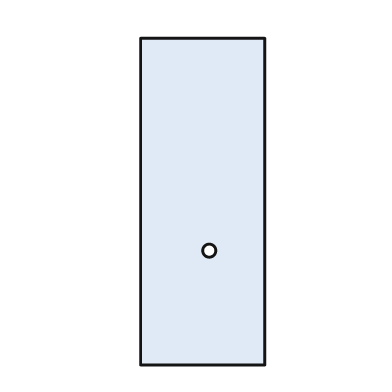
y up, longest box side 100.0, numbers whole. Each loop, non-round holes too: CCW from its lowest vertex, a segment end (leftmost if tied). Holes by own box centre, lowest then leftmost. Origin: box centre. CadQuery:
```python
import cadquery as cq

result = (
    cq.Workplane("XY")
    .moveTo(-19.0, -50.0)
    .lineTo(19.0, -50.0)
    .lineTo(19.0, 50.0)
    .lineTo(-19.0, 50.0)
    .close()
    .moveTo(2.0, -15.0)
    .circle(2.0)
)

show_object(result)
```